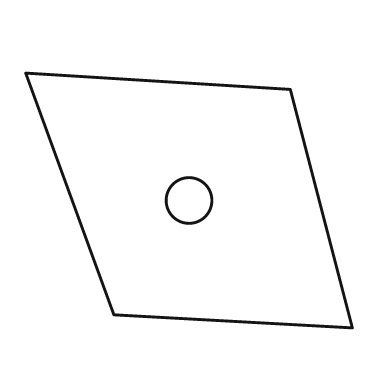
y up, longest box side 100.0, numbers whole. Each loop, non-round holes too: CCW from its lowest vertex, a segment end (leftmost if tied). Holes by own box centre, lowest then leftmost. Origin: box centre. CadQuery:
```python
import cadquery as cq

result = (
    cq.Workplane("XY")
    .moveTo(50.0, -39.0)
    .lineTo(31.0, 34.0)
    .lineTo(-50.0, 39.0)
    .lineTo(-23.0, -35.0)
    .close()
    .moveTo(0.0, 0.0)
    .circle(7.0)
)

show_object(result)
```